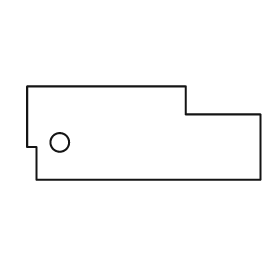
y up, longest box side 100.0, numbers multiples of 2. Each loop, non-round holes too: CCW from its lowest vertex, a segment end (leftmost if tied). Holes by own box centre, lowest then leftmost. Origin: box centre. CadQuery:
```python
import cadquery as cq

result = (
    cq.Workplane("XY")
    .moveTo(-46.0, -20.0)
    .lineTo(50.0, -20.0)
    .lineTo(50.0, 8.0)
    .lineTo(18.0, 8.0)
    .lineTo(18.0, 20.0)
    .lineTo(-50.0, 20.0)
    .lineTo(-50.0, -6.0)
    .lineTo(-46.0, -6.0)
    .close()
    .moveTo(-36.0, -4.0)
    .circle(4.0)
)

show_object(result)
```